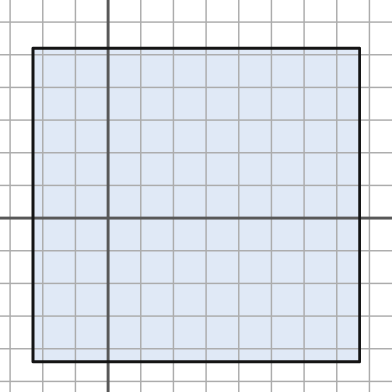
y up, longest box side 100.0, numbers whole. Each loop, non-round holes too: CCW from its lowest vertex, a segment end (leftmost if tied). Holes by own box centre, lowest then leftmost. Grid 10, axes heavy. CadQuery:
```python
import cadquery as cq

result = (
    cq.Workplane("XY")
    .moveTo(-23.0, -44.0)
    .lineTo(77.0, -44.0)
    .lineTo(77.0, 52.0)
    .lineTo(-23.0, 52.0)
    .close()
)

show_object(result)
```